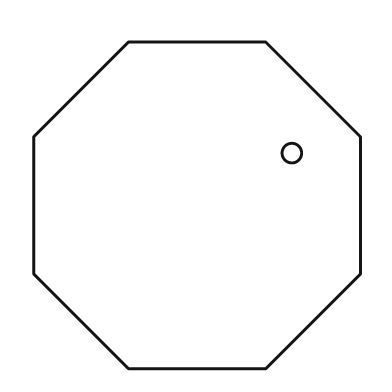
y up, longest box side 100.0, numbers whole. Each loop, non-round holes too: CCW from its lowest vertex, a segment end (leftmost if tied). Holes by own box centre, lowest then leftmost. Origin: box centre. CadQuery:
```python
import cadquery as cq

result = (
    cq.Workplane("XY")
    .moveTo(-21.0, -50.0)
    .lineTo(21.0, -50.0)
    .lineTo(50.0, -21.0)
    .lineTo(50.0, 21.0)
    .lineTo(21.0, 50.0)
    .lineTo(-21.0, 50.0)
    .lineTo(-50.0, 21.0)
    .lineTo(-50.0, -21.0)
    .close()
    .moveTo(29.0, 16.0)
    .circle(3.0)
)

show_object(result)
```